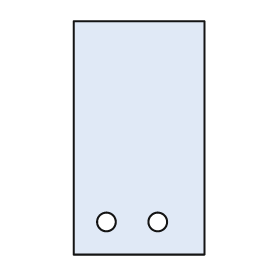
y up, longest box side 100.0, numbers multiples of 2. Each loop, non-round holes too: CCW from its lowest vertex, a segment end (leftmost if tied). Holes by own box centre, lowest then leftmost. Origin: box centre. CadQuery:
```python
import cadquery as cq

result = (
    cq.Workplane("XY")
    .moveTo(-28.0, -50.0)
    .lineTo(28.0, -50.0)
    .lineTo(28.0, 50.0)
    .lineTo(-28.0, 50.0)
    .close()
    .moveTo(-14.0, -36.0)
    .circle(4.0)
    .moveTo(8.0, -36.0)
    .circle(4.0)
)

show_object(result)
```